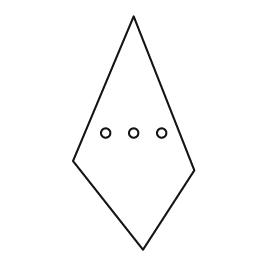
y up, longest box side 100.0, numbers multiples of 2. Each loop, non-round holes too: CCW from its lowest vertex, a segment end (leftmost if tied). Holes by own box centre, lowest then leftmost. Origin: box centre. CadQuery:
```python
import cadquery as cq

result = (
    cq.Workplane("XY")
    .moveTo(4.0, -50.0)
    .lineTo(26.0, -16.0)
    .lineTo(0.0, 50.0)
    .lineTo(-26.0, -12.0)
    .close()
    .moveTo(-12.0, 0.0)
    .circle(2.0)
    .moveTo(0.0, 0.0)
    .circle(2.0)
    .moveTo(12.0, 0.0)
    .circle(2.0)
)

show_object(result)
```